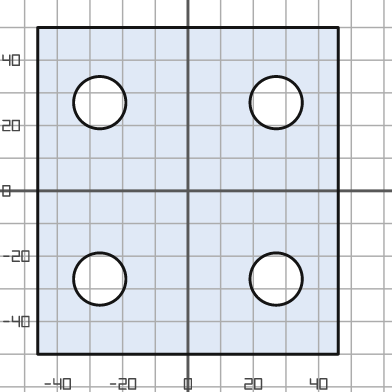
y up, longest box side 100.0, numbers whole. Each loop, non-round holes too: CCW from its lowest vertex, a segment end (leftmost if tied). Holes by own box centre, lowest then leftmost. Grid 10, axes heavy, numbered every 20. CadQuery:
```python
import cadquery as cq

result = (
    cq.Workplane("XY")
    .moveTo(-46.0, -50.0)
    .lineTo(46.0, -50.0)
    .lineTo(46.0, 50.0)
    .lineTo(-46.0, 50.0)
    .close()
    .moveTo(-27.0, -27.0)
    .circle(8.0)
    .moveTo(27.0, -27.0)
    .circle(8.0)
    .moveTo(-27.0, 27.0)
    .circle(8.0)
    .moveTo(27.0, 27.0)
    .circle(8.0)
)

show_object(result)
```